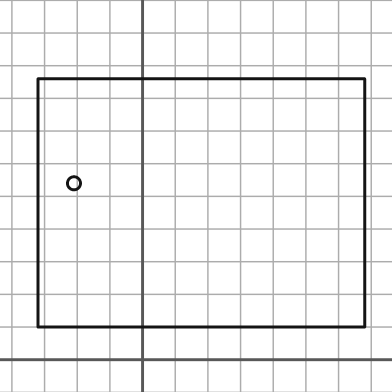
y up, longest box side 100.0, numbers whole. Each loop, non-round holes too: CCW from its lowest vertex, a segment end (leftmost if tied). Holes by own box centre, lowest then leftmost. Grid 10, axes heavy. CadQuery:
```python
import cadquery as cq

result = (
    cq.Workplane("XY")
    .moveTo(-32.0, 10.0)
    .lineTo(68.0, 10.0)
    .lineTo(68.0, 86.0)
    .lineTo(-32.0, 86.0)
    .close()
    .moveTo(-21.0, 54.0)
    .circle(2.0)
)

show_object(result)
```